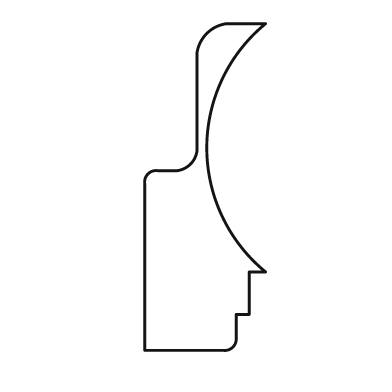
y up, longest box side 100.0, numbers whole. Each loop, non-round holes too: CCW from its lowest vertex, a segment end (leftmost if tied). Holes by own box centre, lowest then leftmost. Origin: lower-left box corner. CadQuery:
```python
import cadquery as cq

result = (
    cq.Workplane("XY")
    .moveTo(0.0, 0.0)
    .lineTo(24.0, 0.0)
    .threePointArc((27.0, 1.0), (28.0, 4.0))
    .lineTo(28.0, 11.0)
    .lineTo(32.0, 11.0)
    .lineTo(32.0, 24.0)
    .lineTo(37.0, 24.0)
    .threePointArc((19.0, 62.0), (37.0, 100.0))
    .lineTo(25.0, 100.0)
    .threePointArc((19.0, 97.0), (16.0, 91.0))
    .lineTo(16.0, 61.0)
    .threePointArc((14.0, 57.0), (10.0, 55.0))
    .lineTo(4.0, 55.0)
    .threePointArc((1.0, 54.0), (0.0, 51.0))
    .close()
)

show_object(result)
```